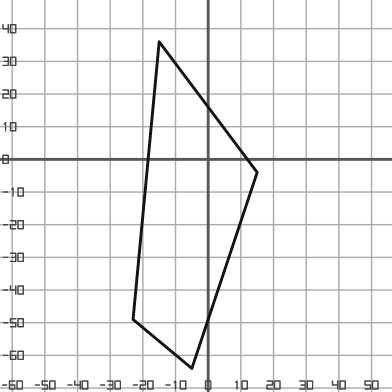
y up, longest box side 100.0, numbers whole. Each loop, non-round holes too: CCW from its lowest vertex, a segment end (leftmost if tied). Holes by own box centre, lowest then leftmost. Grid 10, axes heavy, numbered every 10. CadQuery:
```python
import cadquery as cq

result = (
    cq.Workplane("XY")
    .moveTo(-5.0, -64.0)
    .lineTo(15.0, -4.0)
    .lineTo(-15.0, 36.0)
    .lineTo(-23.0, -49.0)
    .close()
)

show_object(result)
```